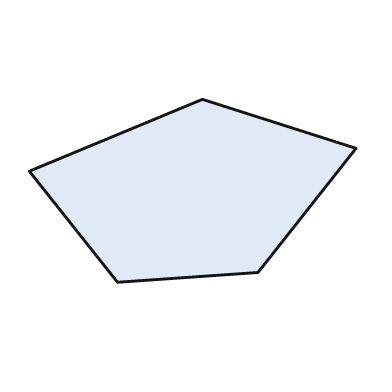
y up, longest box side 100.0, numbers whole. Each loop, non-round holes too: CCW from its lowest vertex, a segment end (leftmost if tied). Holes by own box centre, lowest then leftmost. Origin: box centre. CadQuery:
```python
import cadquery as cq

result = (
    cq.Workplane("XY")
    .moveTo(-23.0, -28.0)
    .lineTo(20.0, -25.0)
    .lineTo(50.0, 13.0)
    .lineTo(3.0, 28.0)
    .lineTo(-50.0, 6.0)
    .close()
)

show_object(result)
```